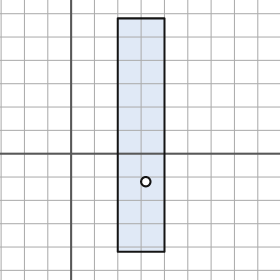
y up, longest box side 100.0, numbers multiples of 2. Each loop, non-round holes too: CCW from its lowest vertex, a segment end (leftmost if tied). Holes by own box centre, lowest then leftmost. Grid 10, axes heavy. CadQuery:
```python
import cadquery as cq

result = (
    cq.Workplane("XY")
    .moveTo(20.0, -42.0)
    .lineTo(40.0, -42.0)
    .lineTo(40.0, 58.0)
    .lineTo(20.0, 58.0)
    .close()
    .moveTo(32.0, -12.0)
    .circle(2.0)
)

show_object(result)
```